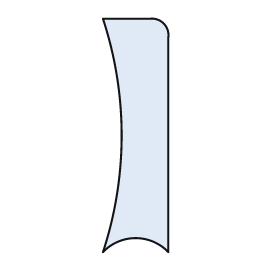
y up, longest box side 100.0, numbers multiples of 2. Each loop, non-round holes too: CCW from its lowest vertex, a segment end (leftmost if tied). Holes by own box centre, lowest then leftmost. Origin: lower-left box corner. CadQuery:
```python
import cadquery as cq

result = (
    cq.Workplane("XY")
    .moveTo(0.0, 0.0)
    .threePointArc((14.0, 6.0), (28.0, 0.0))
    .lineTo(28.0, 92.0)
    .threePointArc((26.0, 98.0), (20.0, 100.0))
    .lineTo(0.0, 100.0)
    .threePointArc((8.0, 50.0), (0.0, 0.0))
    .close()
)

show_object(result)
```